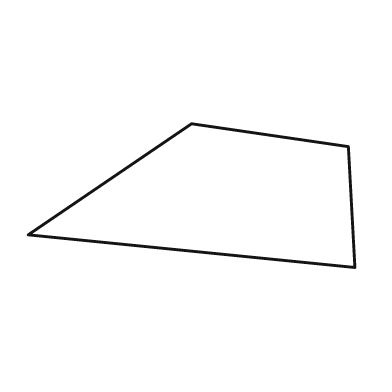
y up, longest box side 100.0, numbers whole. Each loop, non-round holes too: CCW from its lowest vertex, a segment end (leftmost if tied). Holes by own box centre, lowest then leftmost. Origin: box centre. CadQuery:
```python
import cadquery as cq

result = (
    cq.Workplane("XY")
    .moveTo(50.0, -22.0)
    .lineTo(48.0, 15.0)
    .lineTo(0.0, 22.0)
    .lineTo(-50.0, -12.0)
    .close()
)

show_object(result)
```